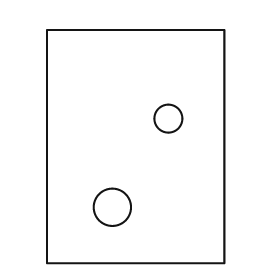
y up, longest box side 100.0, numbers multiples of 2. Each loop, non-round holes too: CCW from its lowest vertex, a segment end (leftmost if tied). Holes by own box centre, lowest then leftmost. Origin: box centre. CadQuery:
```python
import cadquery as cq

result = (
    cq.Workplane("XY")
    .moveTo(-38.0, -50.0)
    .lineTo(38.0, -50.0)
    .lineTo(38.0, 50.0)
    .lineTo(-38.0, 50.0)
    .close()
    .moveTo(-10.0, -26.0)
    .circle(8.0)
    .moveTo(14.0, 12.0)
    .circle(6.0)
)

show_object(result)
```